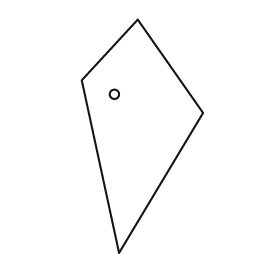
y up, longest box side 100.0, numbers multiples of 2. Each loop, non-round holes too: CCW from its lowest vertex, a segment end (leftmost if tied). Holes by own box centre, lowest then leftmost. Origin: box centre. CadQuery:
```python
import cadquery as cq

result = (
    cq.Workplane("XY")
    .moveTo(-10.0, -50.0)
    .lineTo(26.0, 10.0)
    .lineTo(-2.0, 50.0)
    .lineTo(-26.0, 24.0)
    .close()
    .moveTo(-12.0, 18.0)
    .circle(2.0)
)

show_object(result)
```